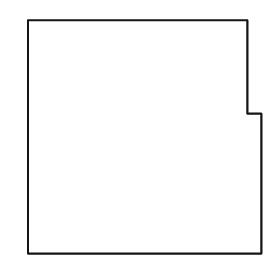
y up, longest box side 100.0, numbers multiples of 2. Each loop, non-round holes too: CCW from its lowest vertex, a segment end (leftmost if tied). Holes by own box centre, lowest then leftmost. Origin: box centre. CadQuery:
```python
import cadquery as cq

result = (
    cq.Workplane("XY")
    .moveTo(-50.0, -50.0)
    .lineTo(50.0, -50.0)
    .lineTo(50.0, 10.0)
    .lineTo(44.0, 10.0)
    .lineTo(44.0, 50.0)
    .lineTo(-50.0, 50.0)
    .close()
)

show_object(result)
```